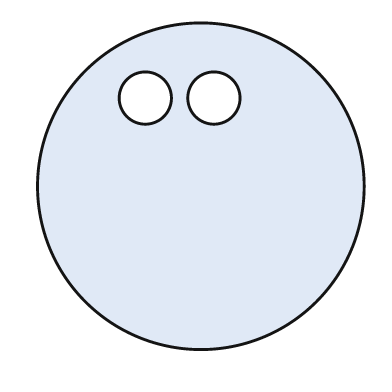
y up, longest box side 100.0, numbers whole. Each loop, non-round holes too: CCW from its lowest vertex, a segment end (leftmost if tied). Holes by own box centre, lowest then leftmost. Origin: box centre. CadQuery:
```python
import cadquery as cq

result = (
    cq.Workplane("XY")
    .moveTo(0.0, 0.0)
    .circle(50.0)
    .moveTo(-17.0, 27.0)
    .circle(8.0)
    .moveTo(4.0, 27.0)
    .circle(8.0)
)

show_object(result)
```